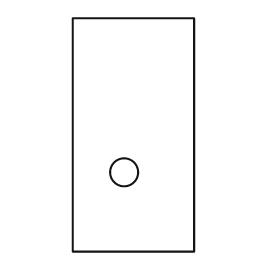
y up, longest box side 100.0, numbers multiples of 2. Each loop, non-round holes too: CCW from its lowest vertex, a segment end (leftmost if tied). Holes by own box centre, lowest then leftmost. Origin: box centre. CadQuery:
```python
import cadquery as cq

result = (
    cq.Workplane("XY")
    .moveTo(-26.0, -50.0)
    .lineTo(26.0, -50.0)
    .lineTo(26.0, 50.0)
    .lineTo(-26.0, 50.0)
    .close()
    .moveTo(-4.0, -16.0)
    .circle(6.0)
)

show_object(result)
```